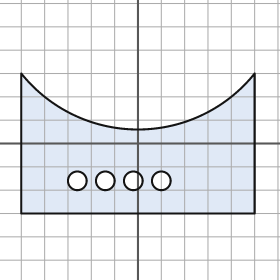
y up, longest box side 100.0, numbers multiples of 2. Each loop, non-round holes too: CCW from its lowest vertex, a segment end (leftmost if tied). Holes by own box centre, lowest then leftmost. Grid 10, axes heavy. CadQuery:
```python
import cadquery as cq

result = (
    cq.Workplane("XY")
    .moveTo(-50.0, -30.0)
    .lineTo(50.0, -30.0)
    .lineTo(50.0, 30.0)
    .threePointArc((0.0, 6.0), (-50.0, 30.0))
    .close()
    .moveTo(-26.0, -16.0)
    .circle(4.0)
    .moveTo(-14.0, -16.0)
    .circle(4.0)
    .moveTo(-2.0, -16.0)
    .circle(4.0)
    .moveTo(10.0, -16.0)
    .circle(4.0)
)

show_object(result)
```